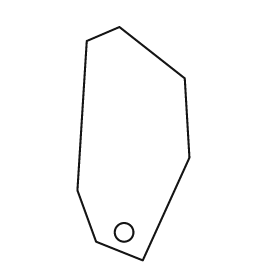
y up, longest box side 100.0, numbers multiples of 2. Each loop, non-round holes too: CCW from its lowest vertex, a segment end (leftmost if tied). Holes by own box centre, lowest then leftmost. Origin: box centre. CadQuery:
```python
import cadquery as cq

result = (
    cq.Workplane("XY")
    .moveTo(4.0, -50.0)
    .lineTo(24.0, -6.0)
    .lineTo(22.0, 28.0)
    .lineTo(-6.0, 50.0)
    .lineTo(-20.0, 44.0)
    .lineTo(-24.0, -20.0)
    .lineTo(-16.0, -42.0)
    .close()
    .moveTo(-4.0, -38.0)
    .circle(4.0)
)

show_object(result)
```